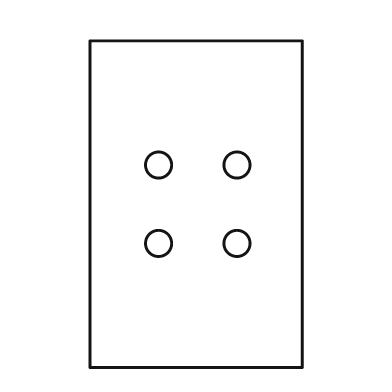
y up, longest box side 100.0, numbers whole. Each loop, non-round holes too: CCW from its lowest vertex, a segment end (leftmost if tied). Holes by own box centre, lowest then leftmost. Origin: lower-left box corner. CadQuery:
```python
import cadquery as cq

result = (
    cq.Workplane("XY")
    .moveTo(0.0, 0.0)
    .lineTo(65.0, 0.0)
    .lineTo(65.0, 100.0)
    .lineTo(0.0, 100.0)
    .close()
    .moveTo(21.0, 38.0)
    .circle(4.0)
    .moveTo(45.0, 38.0)
    .circle(4.0)
    .moveTo(21.0, 62.0)
    .circle(4.0)
    .moveTo(45.0, 62.0)
    .circle(4.0)
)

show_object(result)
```